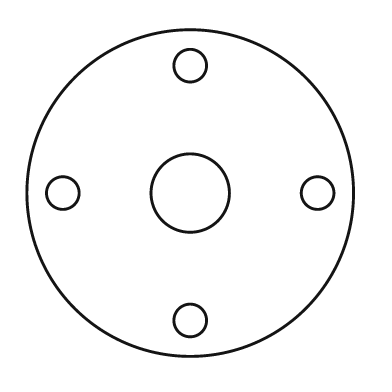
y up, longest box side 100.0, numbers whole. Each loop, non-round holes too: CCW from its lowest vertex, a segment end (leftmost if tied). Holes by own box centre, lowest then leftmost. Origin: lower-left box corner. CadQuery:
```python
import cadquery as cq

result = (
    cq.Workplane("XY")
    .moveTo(50.0, 50.0)
    .circle(50.0)
    .moveTo(50.0, 11.0)
    .circle(5.0)
    .moveTo(11.0, 50.0)
    .circle(5.0)
    .moveTo(50.0, 50.0)
    .circle(12.0)
    .moveTo(89.0, 50.0)
    .circle(5.0)
    .moveTo(50.0, 89.0)
    .circle(5.0)
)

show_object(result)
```